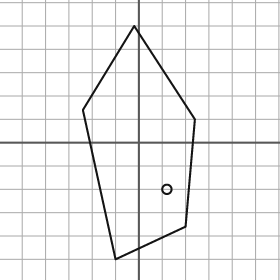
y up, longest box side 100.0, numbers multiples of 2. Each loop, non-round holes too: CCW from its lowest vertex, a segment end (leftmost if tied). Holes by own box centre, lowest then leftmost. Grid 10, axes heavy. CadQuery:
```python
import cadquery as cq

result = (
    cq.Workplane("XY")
    .moveTo(-10.0, -50.0)
    .lineTo(20.0, -36.0)
    .lineTo(24.0, 10.0)
    .lineTo(-2.0, 50.0)
    .lineTo(-24.0, 14.0)
    .close()
    .moveTo(12.0, -20.0)
    .circle(2.0)
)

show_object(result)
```